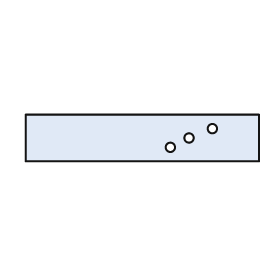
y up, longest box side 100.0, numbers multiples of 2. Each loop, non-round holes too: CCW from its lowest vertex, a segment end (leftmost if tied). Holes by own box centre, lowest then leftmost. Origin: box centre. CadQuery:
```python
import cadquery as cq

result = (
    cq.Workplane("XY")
    .moveTo(-50.0, -10.0)
    .lineTo(50.0, -10.0)
    .lineTo(50.0, 10.0)
    .lineTo(-50.0, 10.0)
    .close()
    .moveTo(12.0, -4.0)
    .circle(2.0)
    .moveTo(20.0, 0.0)
    .circle(2.0)
    .moveTo(30.0, 4.0)
    .circle(2.0)
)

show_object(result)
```